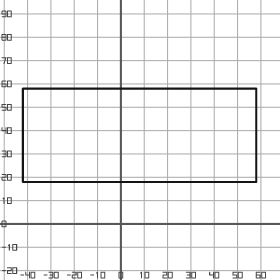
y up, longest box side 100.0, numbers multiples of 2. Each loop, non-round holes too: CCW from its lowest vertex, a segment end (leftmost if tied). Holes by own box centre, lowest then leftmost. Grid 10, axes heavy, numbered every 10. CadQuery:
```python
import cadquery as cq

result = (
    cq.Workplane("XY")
    .moveTo(-42.0, 18.0)
    .lineTo(58.0, 18.0)
    .lineTo(58.0, 58.0)
    .lineTo(-42.0, 58.0)
    .close()
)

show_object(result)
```